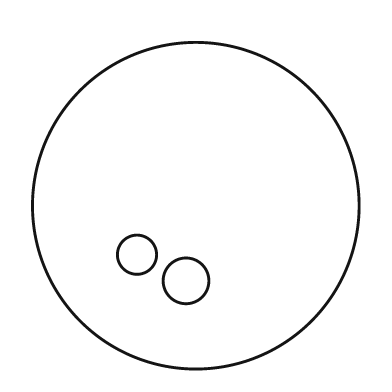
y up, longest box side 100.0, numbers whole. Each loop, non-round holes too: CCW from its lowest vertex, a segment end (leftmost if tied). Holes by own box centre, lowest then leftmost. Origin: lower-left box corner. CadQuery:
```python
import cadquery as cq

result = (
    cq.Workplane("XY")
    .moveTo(50.0, 50.0)
    .circle(50.0)
    .moveTo(47.0, 27.0)
    .circle(7.0)
    .moveTo(32.0, 35.0)
    .circle(6.0)
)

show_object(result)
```